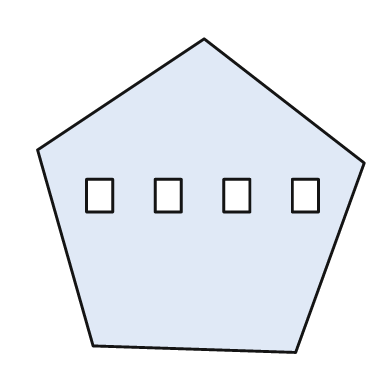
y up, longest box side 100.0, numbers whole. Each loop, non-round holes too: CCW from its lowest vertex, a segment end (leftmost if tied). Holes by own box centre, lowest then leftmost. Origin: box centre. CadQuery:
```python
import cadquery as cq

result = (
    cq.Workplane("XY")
    .moveTo(29.0, -48.0)
    .lineTo(50.0, 10.0)
    .lineTo(1.0, 48.0)
    .lineTo(-50.0, 14.0)
    .lineTo(-33.0, -46.0)
    .close()
    .moveTo(-35.0, -5.0)
    .lineTo(-27.0, -5.0)
    .lineTo(-27.0, 5.0)
    .lineTo(-35.0, 5.0)
    .close()
    .moveTo(-14.0, -5.0)
    .lineTo(-6.0, -5.0)
    .lineTo(-6.0, 5.0)
    .lineTo(-14.0, 5.0)
    .close()
    .moveTo(7.0, -5.0)
    .lineTo(15.0, -5.0)
    .lineTo(15.0, 5.0)
    .lineTo(7.0, 5.0)
    .close()
    .moveTo(28.0, -5.0)
    .lineTo(36.0, -5.0)
    .lineTo(36.0, 5.0)
    .lineTo(28.0, 5.0)
    .close()
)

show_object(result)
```